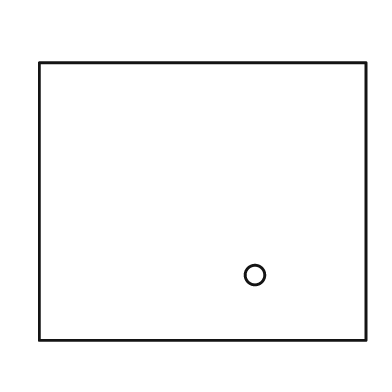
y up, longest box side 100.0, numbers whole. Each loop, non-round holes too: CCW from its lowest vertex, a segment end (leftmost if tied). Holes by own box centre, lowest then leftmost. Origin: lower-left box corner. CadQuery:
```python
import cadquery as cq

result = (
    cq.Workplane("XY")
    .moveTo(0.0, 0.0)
    .lineTo(100.0, 0.0)
    .lineTo(100.0, 85.0)
    .lineTo(0.0, 85.0)
    .close()
    .moveTo(66.0, 20.0)
    .circle(3.0)
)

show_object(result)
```